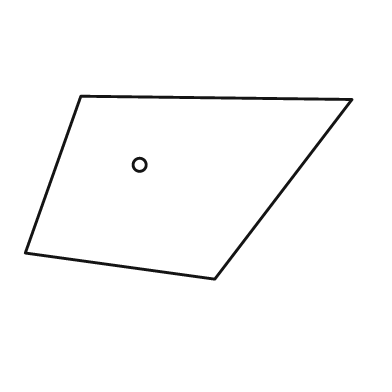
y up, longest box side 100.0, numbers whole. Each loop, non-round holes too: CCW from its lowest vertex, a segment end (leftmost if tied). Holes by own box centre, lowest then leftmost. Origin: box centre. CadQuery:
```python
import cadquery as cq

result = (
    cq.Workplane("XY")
    .moveTo(8.0, -28.0)
    .lineTo(50.0, 27.0)
    .lineTo(-33.0, 28.0)
    .lineTo(-50.0, -20.0)
    .close()
    .moveTo(-15.0, 7.0)
    .circle(2.0)
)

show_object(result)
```